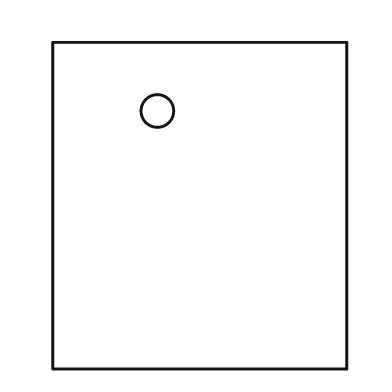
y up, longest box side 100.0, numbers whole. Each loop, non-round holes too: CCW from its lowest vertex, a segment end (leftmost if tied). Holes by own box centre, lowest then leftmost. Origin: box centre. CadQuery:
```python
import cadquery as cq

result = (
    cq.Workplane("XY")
    .moveTo(-45.0, -50.0)
    .lineTo(45.0, -50.0)
    .lineTo(45.0, 50.0)
    .lineTo(-45.0, 50.0)
    .close()
    .moveTo(-13.0, 29.0)
    .circle(5.0)
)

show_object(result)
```